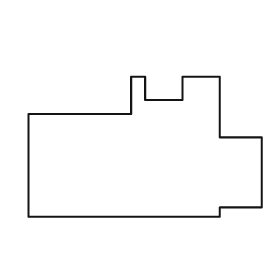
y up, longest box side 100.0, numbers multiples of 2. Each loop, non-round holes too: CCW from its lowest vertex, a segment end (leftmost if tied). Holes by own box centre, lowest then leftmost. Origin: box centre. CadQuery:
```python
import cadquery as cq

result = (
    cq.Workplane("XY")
    .moveTo(-50.0, -30.0)
    .lineTo(32.0, -30.0)
    .lineTo(32.0, -26.0)
    .lineTo(50.0, -26.0)
    .lineTo(50.0, 4.0)
    .lineTo(32.0, 4.0)
    .lineTo(32.0, 30.0)
    .lineTo(16.0, 30.0)
    .lineTo(16.0, 20.0)
    .lineTo(0.0, 20.0)
    .lineTo(0.0, 30.0)
    .lineTo(-6.0, 30.0)
    .lineTo(-6.0, 14.0)
    .lineTo(-50.0, 14.0)
    .close()
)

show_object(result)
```